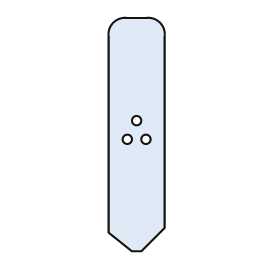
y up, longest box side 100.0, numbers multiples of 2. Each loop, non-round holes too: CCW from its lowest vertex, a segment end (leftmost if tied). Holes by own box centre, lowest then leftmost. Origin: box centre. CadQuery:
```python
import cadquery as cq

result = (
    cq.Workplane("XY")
    .moveTo(-2.0, -50.0)
    .lineTo(2.0, -50.0)
    .lineTo(12.0, -40.0)
    .lineTo(12.0, 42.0)
    .threePointArc((10.0, 48.0), (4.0, 50.0))
    .lineTo(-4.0, 50.0)
    .threePointArc((-10.0, 48.0), (-12.0, 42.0))
    .lineTo(-12.0, -42.0)
    .close()
    .moveTo(-4.0, -2.0)
    .circle(2.0)
    .moveTo(4.0, -2.0)
    .circle(2.0)
    .moveTo(0.0, 6.0)
    .circle(2.0)
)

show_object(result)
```